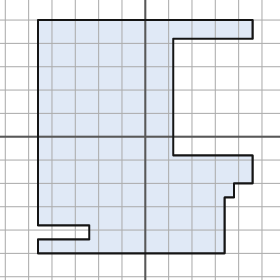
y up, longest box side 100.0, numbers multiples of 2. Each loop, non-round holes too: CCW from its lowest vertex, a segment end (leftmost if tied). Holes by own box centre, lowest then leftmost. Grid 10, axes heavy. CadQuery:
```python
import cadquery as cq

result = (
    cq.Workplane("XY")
    .moveTo(-46.0, -50.0)
    .lineTo(34.0, -50.0)
    .lineTo(34.0, -26.0)
    .lineTo(38.0, -26.0)
    .lineTo(38.0, -20.0)
    .lineTo(46.0, -20.0)
    .lineTo(46.0, -8.0)
    .lineTo(12.0, -8.0)
    .lineTo(12.0, 42.0)
    .lineTo(46.0, 42.0)
    .lineTo(46.0, 50.0)
    .lineTo(-46.0, 50.0)
    .lineTo(-46.0, -38.0)
    .lineTo(-24.0, -38.0)
    .lineTo(-24.0, -44.0)
    .lineTo(-46.0, -44.0)
    .close()
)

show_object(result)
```